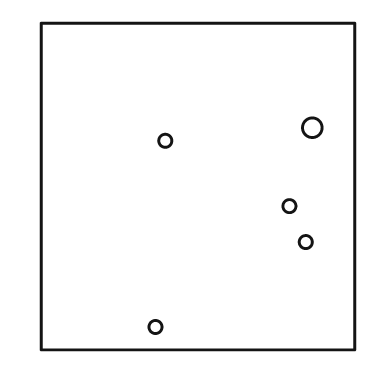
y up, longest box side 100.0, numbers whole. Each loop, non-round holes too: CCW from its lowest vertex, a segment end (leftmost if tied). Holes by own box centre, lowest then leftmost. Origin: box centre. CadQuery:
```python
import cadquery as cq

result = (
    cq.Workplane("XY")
    .moveTo(-48.0, -50.0)
    .lineTo(48.0, -50.0)
    .lineTo(48.0, 50.0)
    .lineTo(-48.0, 50.0)
    .close()
    .moveTo(-13.0, -43.0)
    .circle(2.0)
    .moveTo(33.0, -17.0)
    .circle(2.0)
    .moveTo(28.0, -6.0)
    .circle(2.0)
    .moveTo(-10.0, 14.0)
    .circle(2.0)
    .moveTo(35.0, 18.0)
    .circle(3.0)
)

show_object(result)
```